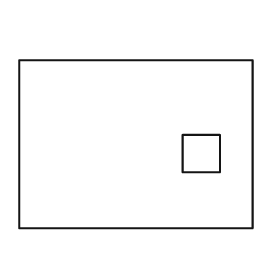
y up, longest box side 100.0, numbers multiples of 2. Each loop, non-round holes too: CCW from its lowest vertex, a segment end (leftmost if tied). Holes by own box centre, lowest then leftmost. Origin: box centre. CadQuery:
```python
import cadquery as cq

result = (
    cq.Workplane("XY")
    .moveTo(-50.0, -36.0)
    .lineTo(50.0, -36.0)
    .lineTo(50.0, 36.0)
    .lineTo(-50.0, 36.0)
    .close()
    .moveTo(20.0, -12.0)
    .lineTo(36.0, -12.0)
    .lineTo(36.0, 4.0)
    .lineTo(20.0, 4.0)
    .close()
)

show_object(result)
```